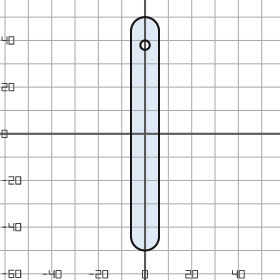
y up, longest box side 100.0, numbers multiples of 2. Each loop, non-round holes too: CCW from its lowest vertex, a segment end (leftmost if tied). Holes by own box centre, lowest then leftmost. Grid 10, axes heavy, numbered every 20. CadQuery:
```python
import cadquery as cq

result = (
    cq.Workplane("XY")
    .moveTo(-6.0, -44.0)
    .threePointArc((0.0, -50.0), (6.0, -44.0))
    .lineTo(6.0, 44.0)
    .threePointArc((0.0, 50.0), (-6.0, 44.0))
    .close()
    .moveTo(0.0, 38.0)
    .circle(2.0)
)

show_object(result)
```